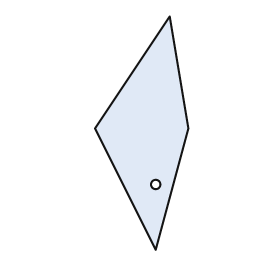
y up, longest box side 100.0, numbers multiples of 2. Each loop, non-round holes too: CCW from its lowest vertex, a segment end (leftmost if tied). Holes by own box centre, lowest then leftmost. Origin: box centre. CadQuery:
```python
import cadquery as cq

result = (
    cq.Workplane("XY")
    .moveTo(6.0, -50.0)
    .lineTo(20.0, 2.0)
    .lineTo(12.0, 50.0)
    .lineTo(-20.0, 2.0)
    .close()
    .moveTo(6.0, -22.0)
    .circle(2.0)
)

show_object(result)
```